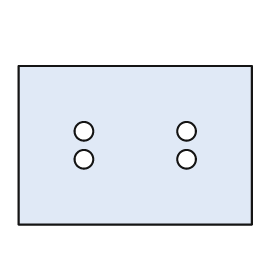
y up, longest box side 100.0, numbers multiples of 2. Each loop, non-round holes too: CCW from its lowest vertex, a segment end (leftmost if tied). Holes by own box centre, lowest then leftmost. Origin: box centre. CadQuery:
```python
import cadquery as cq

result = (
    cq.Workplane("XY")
    .moveTo(-50.0, -34.0)
    .lineTo(50.0, -34.0)
    .lineTo(50.0, 34.0)
    .lineTo(-50.0, 34.0)
    .close()
    .moveTo(-22.0, -6.0)
    .circle(4.0)
    .moveTo(22.0, -6.0)
    .circle(4.0)
    .moveTo(-22.0, 6.0)
    .circle(4.0)
    .moveTo(22.0, 6.0)
    .circle(4.0)
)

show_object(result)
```